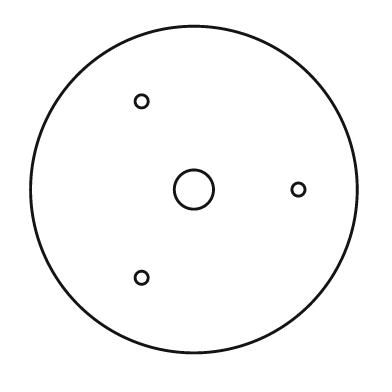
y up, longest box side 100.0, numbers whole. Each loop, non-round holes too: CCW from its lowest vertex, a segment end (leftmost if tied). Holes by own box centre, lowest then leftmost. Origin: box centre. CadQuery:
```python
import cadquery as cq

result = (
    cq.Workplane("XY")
    .moveTo(0.0, 0.0)
    .circle(50.0)
    .moveTo(-16.0, -27.0)
    .circle(2.0)
    .moveTo(0.0, 0.0)
    .circle(6.0)
    .moveTo(32.0, 0.0)
    .circle(2.0)
    .moveTo(-16.0, 27.0)
    .circle(2.0)
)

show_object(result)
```